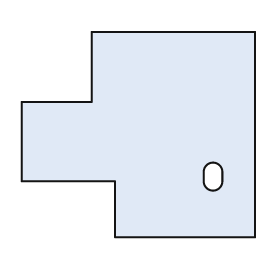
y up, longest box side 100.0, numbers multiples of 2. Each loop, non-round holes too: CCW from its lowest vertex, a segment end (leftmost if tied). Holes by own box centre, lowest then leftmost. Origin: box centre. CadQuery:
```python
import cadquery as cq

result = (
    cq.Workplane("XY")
    .moveTo(-10.0, -44.0)
    .lineTo(50.0, -44.0)
    .lineTo(50.0, 44.0)
    .lineTo(-20.0, 44.0)
    .lineTo(-20.0, 14.0)
    .lineTo(-50.0, 14.0)
    .lineTo(-50.0, -20.0)
    .lineTo(-10.0, -20.0)
    .close()
    .moveTo(28.0, -20.0)
    .threePointArc((32.0, -24.0), (36.0, -20.0))
    .lineTo(36.0, -16.0)
    .threePointArc((32.0, -12.0), (28.0, -16.0))
    .close()
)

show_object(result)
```